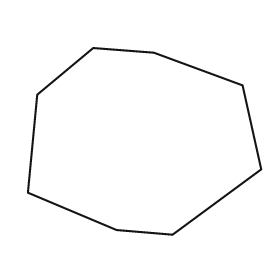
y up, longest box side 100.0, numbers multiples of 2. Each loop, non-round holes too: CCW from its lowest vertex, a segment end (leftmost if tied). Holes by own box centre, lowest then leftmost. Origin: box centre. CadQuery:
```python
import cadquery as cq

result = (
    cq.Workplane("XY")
    .moveTo(12.0, -40.0)
    .lineTo(50.0, -12.0)
    .lineTo(42.0, 24.0)
    .lineTo(4.0, 38.0)
    .lineTo(-22.0, 40.0)
    .lineTo(-46.0, 20.0)
    .lineTo(-50.0, -22.0)
    .lineTo(-12.0, -38.0)
    .close()
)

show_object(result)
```